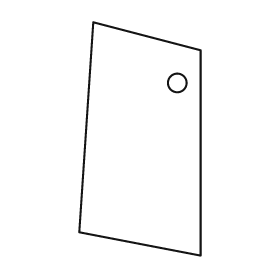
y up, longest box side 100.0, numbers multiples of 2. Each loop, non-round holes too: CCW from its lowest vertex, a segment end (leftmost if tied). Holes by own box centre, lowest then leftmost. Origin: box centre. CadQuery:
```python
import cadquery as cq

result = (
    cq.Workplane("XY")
    .moveTo(26.0, -50.0)
    .lineTo(26.0, 38.0)
    .lineTo(-20.0, 50.0)
    .lineTo(-26.0, -40.0)
    .close()
    .moveTo(16.0, 24.0)
    .circle(4.0)
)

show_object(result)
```